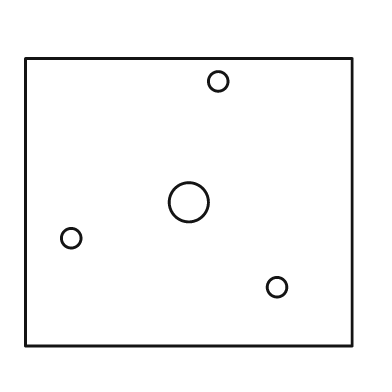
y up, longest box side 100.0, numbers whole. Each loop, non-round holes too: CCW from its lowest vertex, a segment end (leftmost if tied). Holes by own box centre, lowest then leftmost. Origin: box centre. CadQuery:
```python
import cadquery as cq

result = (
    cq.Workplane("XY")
    .moveTo(-50.0, -44.0)
    .lineTo(50.0, -44.0)
    .lineTo(50.0, 44.0)
    .lineTo(-50.0, 44.0)
    .close()
    .moveTo(27.0, -26.0)
    .circle(3.0)
    .moveTo(-36.0, -11.0)
    .circle(3.0)
    .moveTo(0.0, 0.0)
    .circle(6.0)
    .moveTo(9.0, 37.0)
    .circle(3.0)
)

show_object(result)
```